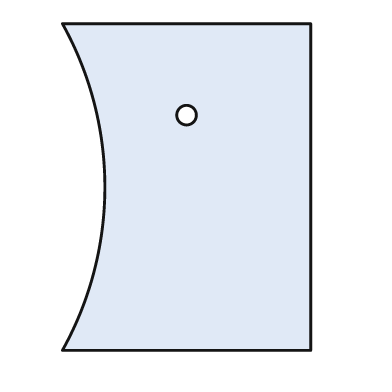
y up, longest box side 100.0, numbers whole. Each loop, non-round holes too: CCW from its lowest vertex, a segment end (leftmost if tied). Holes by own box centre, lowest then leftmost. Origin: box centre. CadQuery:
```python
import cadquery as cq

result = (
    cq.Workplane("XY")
    .moveTo(-38.0, -50.0)
    .lineTo(38.0, -50.0)
    .lineTo(38.0, 50.0)
    .lineTo(-38.0, 50.0)
    .threePointArc((-25.0, 0.0), (-38.0, -50.0))
    .close()
    .moveTo(0.0, 22.0)
    .circle(3.0)
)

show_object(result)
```